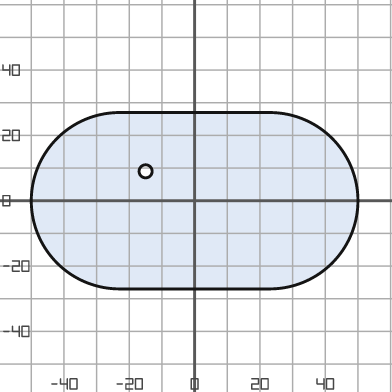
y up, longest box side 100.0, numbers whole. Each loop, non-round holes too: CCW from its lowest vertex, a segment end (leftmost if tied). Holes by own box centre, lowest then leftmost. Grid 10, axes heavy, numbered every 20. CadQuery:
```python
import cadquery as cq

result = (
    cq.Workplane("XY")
    .moveTo(-23.0, -27.0)
    .lineTo(23.0, -27.0)
    .threePointArc((50.0, 0.0), (23.0, 27.0))
    .lineTo(-23.0, 27.0)
    .threePointArc((-50.0, 0.0), (-23.0, -27.0))
    .close()
    .moveTo(-15.0, 9.0)
    .circle(2.0)
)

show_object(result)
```